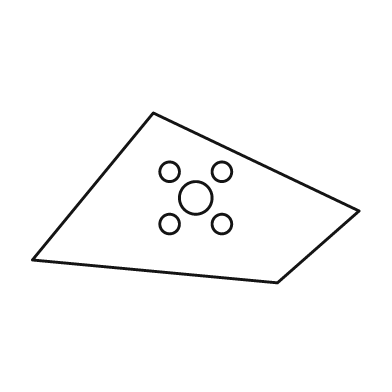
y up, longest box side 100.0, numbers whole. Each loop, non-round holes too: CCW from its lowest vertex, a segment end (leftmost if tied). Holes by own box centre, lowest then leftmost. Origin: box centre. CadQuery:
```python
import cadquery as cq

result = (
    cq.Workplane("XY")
    .moveTo(25.0, -26.0)
    .lineTo(50.0, -4.0)
    .lineTo(-13.0, 26.0)
    .lineTo(-50.0, -19.0)
    .close()
    .moveTo(-8.0, -8.0)
    .circle(3.0)
    .moveTo(8.0, -8.0)
    .circle(3.0)
    .moveTo(0.0, 0.0)
    .circle(5.0)
    .moveTo(-8.0, 8.0)
    .circle(3.0)
    .moveTo(8.0, 8.0)
    .circle(3.0)
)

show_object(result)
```